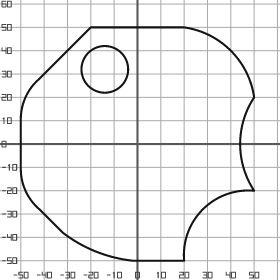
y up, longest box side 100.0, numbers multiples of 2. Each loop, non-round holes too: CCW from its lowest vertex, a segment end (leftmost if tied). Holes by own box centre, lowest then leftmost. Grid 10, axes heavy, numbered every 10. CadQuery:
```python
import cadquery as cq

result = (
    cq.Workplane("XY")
    .moveTo(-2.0, -50.0)
    .lineTo(20.0, -50.0)
    .threePointArc((28.0, -28.0), (50.0, -20.0))
    .threePointArc((44.0, 0.0), (50.0, 20.0))
    .threePointArc((40.0, 40.0), (20.0, 50.0))
    .lineTo(-20.0, 50.0)
    .lineTo(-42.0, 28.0)
    .threePointArc((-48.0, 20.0), (-50.0, 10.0))
    .lineTo(-50.0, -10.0)
    .threePointArc((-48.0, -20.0), (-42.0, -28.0))
    .lineTo(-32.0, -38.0)
    .threePointArc((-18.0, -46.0), (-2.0, -50.0))
    .close()
    .moveTo(-14.0, 32.0)
    .circle(10.0)
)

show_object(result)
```